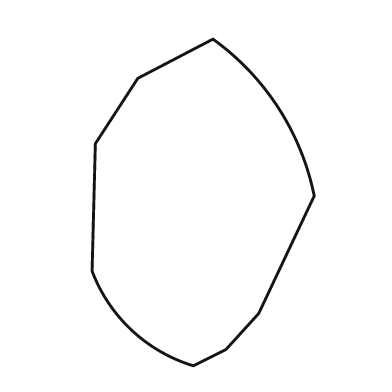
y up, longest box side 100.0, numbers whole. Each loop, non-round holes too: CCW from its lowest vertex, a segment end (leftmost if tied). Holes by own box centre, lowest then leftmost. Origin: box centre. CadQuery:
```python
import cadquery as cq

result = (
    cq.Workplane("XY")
    .moveTo(-3.0, -50.0)
    .lineTo(7.0, -45.0)
    .lineTo(17.0, -34.0)
    .lineTo(34.0, 2.0)
    .threePointArc((23.0, 29.0), (3.0, 50.0))
    .lineTo(-20.0, 38.0)
    .lineTo(-33.0, 18.0)
    .lineTo(-34.0, -21.0)
    .threePointArc((-22.0, -39.0), (-3.0, -50.0))
    .close()
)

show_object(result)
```